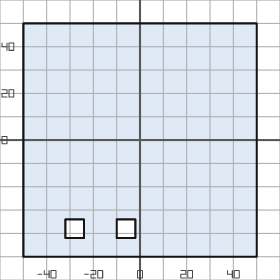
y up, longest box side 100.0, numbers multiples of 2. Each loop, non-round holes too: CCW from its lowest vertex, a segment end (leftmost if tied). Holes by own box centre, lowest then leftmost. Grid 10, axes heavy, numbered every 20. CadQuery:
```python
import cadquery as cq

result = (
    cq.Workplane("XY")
    .moveTo(-50.0, -50.0)
    .lineTo(50.0, -50.0)
    .lineTo(50.0, 50.0)
    .lineTo(-50.0, 50.0)
    .close()
    .moveTo(-32.0, -42.0)
    .lineTo(-24.0, -42.0)
    .lineTo(-24.0, -34.0)
    .lineTo(-32.0, -34.0)
    .close()
    .moveTo(-10.0, -42.0)
    .lineTo(-2.0, -42.0)
    .lineTo(-2.0, -34.0)
    .lineTo(-10.0, -34.0)
    .close()
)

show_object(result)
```